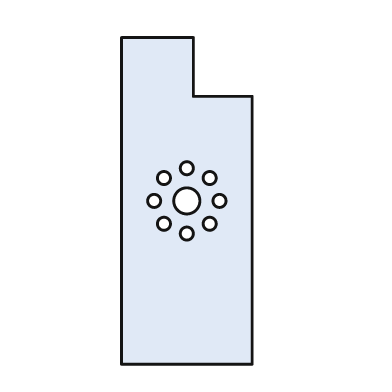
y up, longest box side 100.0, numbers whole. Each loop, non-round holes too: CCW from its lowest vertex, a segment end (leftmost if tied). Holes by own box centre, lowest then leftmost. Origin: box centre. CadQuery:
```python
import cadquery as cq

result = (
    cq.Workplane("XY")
    .moveTo(-20.0, -50.0)
    .lineTo(20.0, -50.0)
    .lineTo(20.0, 32.0)
    .lineTo(2.0, 32.0)
    .lineTo(2.0, 50.0)
    .lineTo(-20.0, 50.0)
    .close()
    .moveTo(0.0, -10.0)
    .circle(2.0)
    .moveTo(-7.0, -7.0)
    .circle(2.0)
    .moveTo(7.0, -7.0)
    .circle(2.0)
    .moveTo(-10.0, 0.0)
    .circle(2.0)
    .moveTo(0.0, 0.0)
    .circle(4.0)
    .moveTo(10.0, 0.0)
    .circle(2.0)
    .moveTo(-7.0, 7.0)
    .circle(2.0)
    .moveTo(7.0, 7.0)
    .circle(2.0)
    .moveTo(0.0, 10.0)
    .circle(2.0)
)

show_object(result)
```